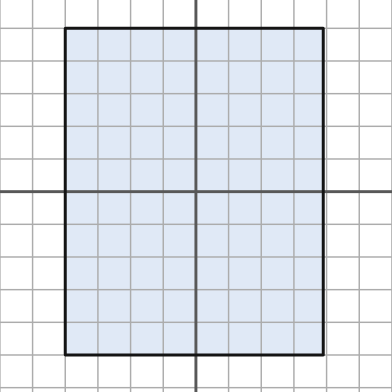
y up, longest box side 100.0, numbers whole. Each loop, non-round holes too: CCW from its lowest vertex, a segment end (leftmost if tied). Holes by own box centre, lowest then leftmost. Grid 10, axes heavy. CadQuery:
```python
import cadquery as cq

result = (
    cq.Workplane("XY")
    .moveTo(-40.0, -50.0)
    .lineTo(39.0, -50.0)
    .lineTo(39.0, 50.0)
    .lineTo(-40.0, 50.0)
    .close()
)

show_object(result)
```